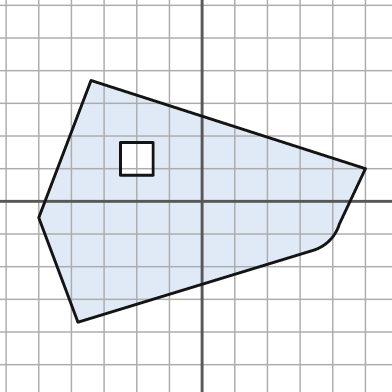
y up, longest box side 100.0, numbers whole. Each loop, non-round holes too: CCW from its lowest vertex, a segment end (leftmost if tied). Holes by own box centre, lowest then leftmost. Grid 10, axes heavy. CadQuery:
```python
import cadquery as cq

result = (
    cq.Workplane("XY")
    .moveTo(-38.0, -37.0)
    .lineTo(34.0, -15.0)
    .threePointArc((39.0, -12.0), (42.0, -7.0))
    .lineTo(50.0, 10.0)
    .lineTo(-34.0, 37.0)
    .lineTo(-50.0, -5.0)
    .close()
    .moveTo(-25.0, 8.0)
    .lineTo(-15.0, 8.0)
    .lineTo(-15.0, 18.0)
    .lineTo(-25.0, 18.0)
    .close()
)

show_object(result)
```